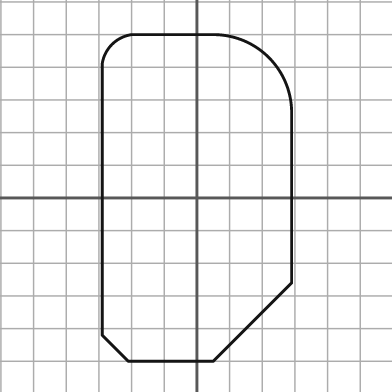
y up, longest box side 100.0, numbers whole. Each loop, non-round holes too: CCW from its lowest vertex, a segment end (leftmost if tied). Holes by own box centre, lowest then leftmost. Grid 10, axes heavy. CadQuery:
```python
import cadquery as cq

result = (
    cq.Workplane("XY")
    .moveTo(-21.0, -50.0)
    .lineTo(5.0, -50.0)
    .lineTo(29.0, -26.0)
    .lineTo(29.0, 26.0)
    .threePointArc((22.0, 43.0), (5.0, 50.0))
    .lineTo(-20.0, 50.0)
    .threePointArc((-26.0, 47.0), (-29.0, 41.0))
    .lineTo(-29.0, -42.0)
    .close()
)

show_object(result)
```